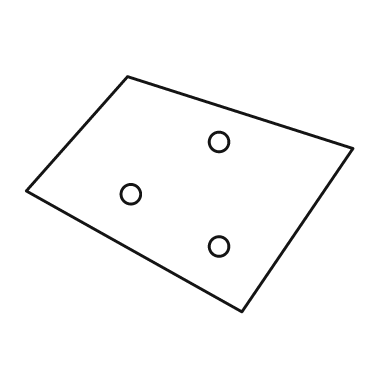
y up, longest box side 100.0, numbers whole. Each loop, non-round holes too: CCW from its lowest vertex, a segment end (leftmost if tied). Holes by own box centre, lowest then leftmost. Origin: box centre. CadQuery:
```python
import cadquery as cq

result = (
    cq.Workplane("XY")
    .moveTo(16.0, -36.0)
    .lineTo(50.0, 14.0)
    .lineTo(-19.0, 36.0)
    .lineTo(-50.0, 1.0)
    .close()
    .moveTo(9.0, -16.0)
    .circle(3.0)
    .moveTo(-18.0, 0.0)
    .circle(3.0)
    .moveTo(9.0, 16.0)
    .circle(3.0)
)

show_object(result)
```